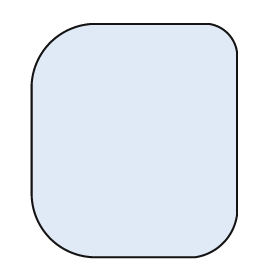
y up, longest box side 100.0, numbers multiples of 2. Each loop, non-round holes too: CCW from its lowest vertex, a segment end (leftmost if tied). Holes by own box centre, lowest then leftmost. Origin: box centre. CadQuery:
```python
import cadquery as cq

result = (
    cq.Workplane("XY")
    .moveTo(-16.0, -50.0)
    .lineTo(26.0, -50.0)
    .threePointArc((38.0, -44.0), (44.0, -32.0))
    .lineTo(44.0, 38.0)
    .threePointArc((40.0, 46.0), (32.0, 50.0))
    .lineTo(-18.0, 50.0)
    .threePointArc((-36.0, 42.0), (-44.0, 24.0))
    .lineTo(-44.0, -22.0)
    .threePointArc((-36.0, -42.0), (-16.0, -50.0))
    .close()
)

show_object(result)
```